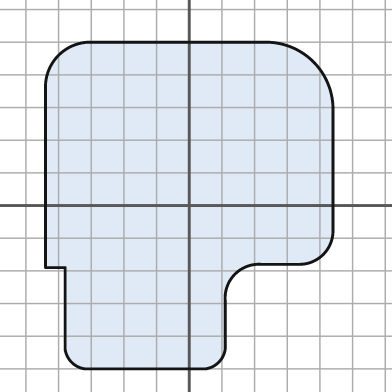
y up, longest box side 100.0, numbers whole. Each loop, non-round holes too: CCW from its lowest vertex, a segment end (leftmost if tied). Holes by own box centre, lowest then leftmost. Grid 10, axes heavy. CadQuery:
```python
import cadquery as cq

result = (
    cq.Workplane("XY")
    .moveTo(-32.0, -50.0)
    .lineTo(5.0, -50.0)
    .threePointArc((9.0, -48.0), (11.0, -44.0))
    .lineTo(11.0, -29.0)
    .threePointArc((14.0, -21.0), (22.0, -18.0))
    .lineTo(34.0, -18.0)
    .threePointArc((41.0, -15.0), (44.0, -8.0))
    .lineTo(44.0, 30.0)
    .threePointArc((38.0, 44.0), (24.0, 50.0))
    .lineTo(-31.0, 50.0)
    .threePointArc((-40.0, 46.0), (-44.0, 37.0))
    .lineTo(-44.0, -19.0)
    .lineTo(-38.0, -19.0)
    .lineTo(-38.0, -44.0)
    .threePointArc((-36.0, -48.0), (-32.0, -50.0))
    .close()
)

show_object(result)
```